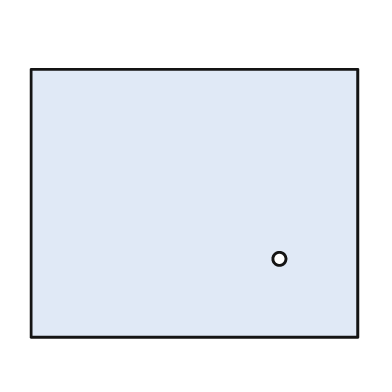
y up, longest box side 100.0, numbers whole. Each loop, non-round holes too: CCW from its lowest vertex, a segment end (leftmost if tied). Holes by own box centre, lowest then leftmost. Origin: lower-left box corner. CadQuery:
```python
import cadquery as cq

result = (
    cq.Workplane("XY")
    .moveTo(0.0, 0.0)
    .lineTo(100.0, 0.0)
    .lineTo(100.0, 82.0)
    .lineTo(0.0, 82.0)
    .close()
    .moveTo(76.0, 24.0)
    .circle(2.0)
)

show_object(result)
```